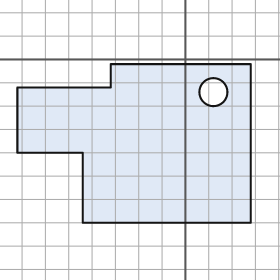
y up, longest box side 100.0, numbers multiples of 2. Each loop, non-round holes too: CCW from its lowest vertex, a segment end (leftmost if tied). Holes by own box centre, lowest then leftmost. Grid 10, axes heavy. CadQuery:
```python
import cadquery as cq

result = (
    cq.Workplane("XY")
    .moveTo(-44.0, -70.0)
    .lineTo(28.0, -70.0)
    .lineTo(28.0, -2.0)
    .lineTo(-32.0, -2.0)
    .lineTo(-32.0, -12.0)
    .lineTo(-72.0, -12.0)
    .lineTo(-72.0, -40.0)
    .lineTo(-44.0, -40.0)
    .close()
    .moveTo(12.0, -14.0)
    .circle(6.0)
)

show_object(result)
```